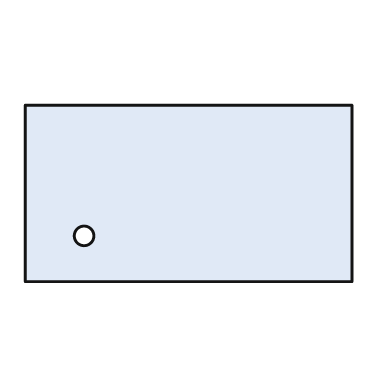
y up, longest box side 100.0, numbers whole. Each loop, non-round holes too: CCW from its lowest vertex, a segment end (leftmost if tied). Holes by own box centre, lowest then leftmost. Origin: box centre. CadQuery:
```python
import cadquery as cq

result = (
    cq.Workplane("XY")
    .moveTo(-50.0, -27.0)
    .lineTo(50.0, -27.0)
    .lineTo(50.0, 27.0)
    .lineTo(-50.0, 27.0)
    .close()
    .moveTo(-32.0, -13.0)
    .circle(3.0)
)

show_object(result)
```